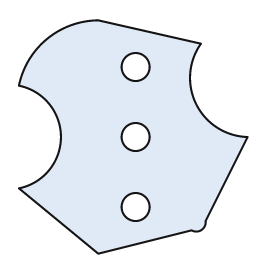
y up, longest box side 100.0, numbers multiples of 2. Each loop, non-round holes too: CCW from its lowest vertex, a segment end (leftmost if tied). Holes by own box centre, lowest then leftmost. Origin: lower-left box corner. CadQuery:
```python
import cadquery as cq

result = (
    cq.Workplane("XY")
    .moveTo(34.0, 0.0)
    .lineTo(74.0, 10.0)
    .threePointArc((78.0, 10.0), (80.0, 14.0))
    .lineTo(98.0, 50.0)
    .threePointArc((76.0, 64.0), (78.0, 90.0))
    .lineTo(34.0, 100.0)
    .threePointArc((12.0, 92.0), (0.0, 72.0))
    .threePointArc((18.0, 50.0), (0.0, 28.0))
    .close()
    .moveTo(50.0, 20.0)
    .circle(6.0)
    .moveTo(50.0, 50.0)
    .circle(6.0)
    .moveTo(50.0, 80.0)
    .circle(6.0)
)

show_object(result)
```